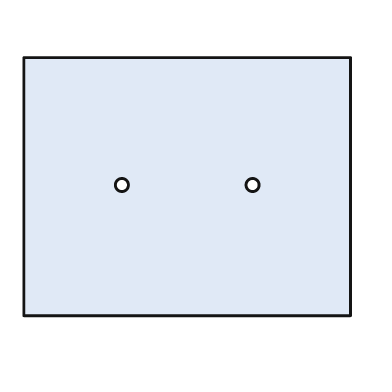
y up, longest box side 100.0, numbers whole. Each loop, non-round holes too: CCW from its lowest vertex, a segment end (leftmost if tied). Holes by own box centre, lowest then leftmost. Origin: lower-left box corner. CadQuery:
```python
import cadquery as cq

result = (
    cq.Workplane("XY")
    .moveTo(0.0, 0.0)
    .lineTo(100.0, 0.0)
    .lineTo(100.0, 79.0)
    .lineTo(0.0, 79.0)
    .close()
    .moveTo(30.0, 40.0)
    .circle(2.0)
    .moveTo(70.0, 40.0)
    .circle(2.0)
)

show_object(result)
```